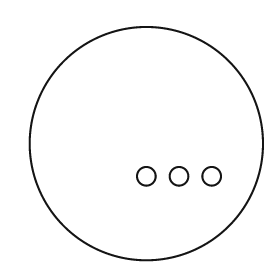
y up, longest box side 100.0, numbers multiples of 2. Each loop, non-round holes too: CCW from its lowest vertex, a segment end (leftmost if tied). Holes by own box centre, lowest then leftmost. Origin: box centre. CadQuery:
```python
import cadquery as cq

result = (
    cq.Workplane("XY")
    .moveTo(0.0, 0.0)
    .circle(50.0)
    .moveTo(0.0, -14.0)
    .circle(4.0)
    .moveTo(14.0, -14.0)
    .circle(4.0)
    .moveTo(28.0, -14.0)
    .circle(4.0)
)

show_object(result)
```